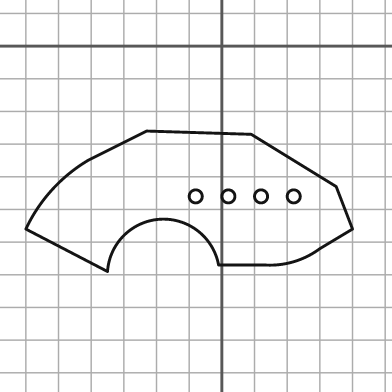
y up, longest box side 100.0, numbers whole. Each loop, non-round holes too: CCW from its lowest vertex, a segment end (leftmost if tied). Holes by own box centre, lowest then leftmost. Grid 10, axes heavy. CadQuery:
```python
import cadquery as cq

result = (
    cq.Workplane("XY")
    .moveTo(-35.0, -69.0)
    .threePointArc((-19.0, -53.0), (-1.0, -67.0))
    .lineTo(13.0, -67.0)
    .threePointArc((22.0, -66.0), (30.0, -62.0))
    .lineTo(40.0, -56.0)
    .lineTo(35.0, -43.0)
    .lineTo(9.0, -27.0)
    .lineTo(-23.0, -26.0)
    .lineTo(-41.0, -35.0)
    .threePointArc((-52.0, -44.0), (-60.0, -56.0))
    .close()
    .moveTo(-8.0, -46.0)
    .circle(2.0)
    .moveTo(2.0, -46.0)
    .circle(2.0)
    .moveTo(12.0, -46.0)
    .circle(2.0)
    .moveTo(22.0, -46.0)
    .circle(2.0)
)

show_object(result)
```